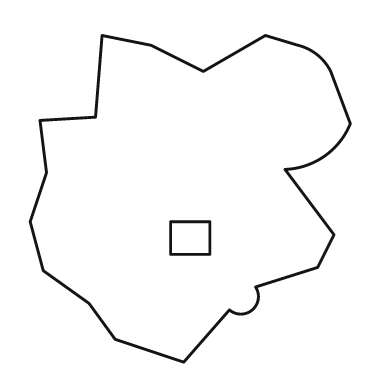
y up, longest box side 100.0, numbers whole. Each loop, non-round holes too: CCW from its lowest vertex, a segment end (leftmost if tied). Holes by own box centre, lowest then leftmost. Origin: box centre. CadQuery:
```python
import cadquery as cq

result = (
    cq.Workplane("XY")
    .moveTo(-2.0, -50.0)
    .lineTo(12.0, -34.0)
    .threePointArc((19.0, -34.0), (20.0, -27.0))
    .lineTo(39.0, -21.0)
    .lineTo(44.0, -11.0)
    .lineTo(29.0, 9.0)
    .threePointArc((41.0, 13.0), (49.0, 23.0))
    .lineTo(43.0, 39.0)
    .threePointArc((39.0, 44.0), (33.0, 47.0))
    .lineTo(23.0, 50.0)
    .lineTo(4.0, 39.0)
    .lineTo(-12.0, 47.0)
    .lineTo(-27.0, 50.0)
    .lineTo(-29.0, 25.0)
    .lineTo(-46.0, 24.0)
    .lineTo(-44.0, 8.0)
    .lineTo(-49.0, -7.0)
    .lineTo(-45.0, -22.0)
    .lineTo(-31.0, -32.0)
    .lineTo(-23.0, -43.0)
    .close()
    .moveTo(-6.0, -17.0)
    .lineTo(6.0, -17.0)
    .lineTo(6.0, -7.0)
    .lineTo(-6.0, -7.0)
    .close()
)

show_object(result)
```